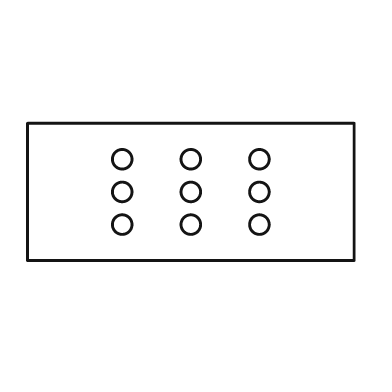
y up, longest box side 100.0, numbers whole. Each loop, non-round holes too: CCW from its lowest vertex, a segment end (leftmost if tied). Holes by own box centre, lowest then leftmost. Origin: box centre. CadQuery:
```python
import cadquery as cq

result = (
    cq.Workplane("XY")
    .moveTo(-50.0, -21.0)
    .lineTo(50.0, -21.0)
    .lineTo(50.0, 21.0)
    .lineTo(-50.0, 21.0)
    .close()
    .moveTo(-21.0, -10.0)
    .circle(3.0)
    .moveTo(0.0, -10.0)
    .circle(3.0)
    .moveTo(21.0, -10.0)
    .circle(3.0)
    .moveTo(-21.0, 0.0)
    .circle(3.0)
    .moveTo(0.0, 0.0)
    .circle(3.0)
    .moveTo(21.0, 0.0)
    .circle(3.0)
    .moveTo(-21.0, 10.0)
    .circle(3.0)
    .moveTo(0.0, 10.0)
    .circle(3.0)
    .moveTo(21.0, 10.0)
    .circle(3.0)
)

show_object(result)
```